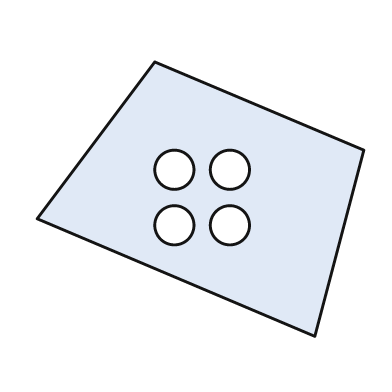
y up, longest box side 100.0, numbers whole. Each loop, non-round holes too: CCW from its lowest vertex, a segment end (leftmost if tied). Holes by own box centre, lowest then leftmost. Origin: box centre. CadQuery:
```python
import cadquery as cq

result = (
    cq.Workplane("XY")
    .moveTo(35.0, -42.0)
    .lineTo(50.0, 15.0)
    .lineTo(-14.0, 42.0)
    .lineTo(-50.0, -6.0)
    .close()
    .moveTo(-8.0, -8.0)
    .circle(6.0)
    .moveTo(9.0, -8.0)
    .circle(6.0)
    .moveTo(-8.0, 9.0)
    .circle(6.0)
    .moveTo(9.0, 9.0)
    .circle(6.0)
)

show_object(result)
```